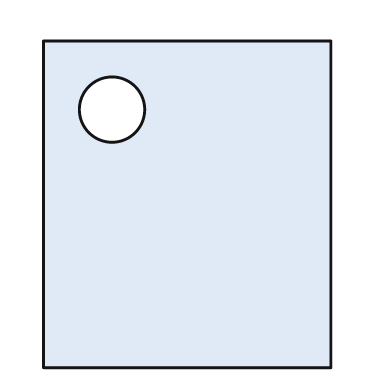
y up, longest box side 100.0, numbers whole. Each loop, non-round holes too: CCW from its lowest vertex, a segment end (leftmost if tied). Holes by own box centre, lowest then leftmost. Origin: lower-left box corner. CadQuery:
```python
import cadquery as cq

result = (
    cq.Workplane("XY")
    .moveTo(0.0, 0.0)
    .lineTo(88.0, 0.0)
    .lineTo(88.0, 100.0)
    .lineTo(0.0, 100.0)
    .close()
    .moveTo(21.0, 79.0)
    .circle(10.0)
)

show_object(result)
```